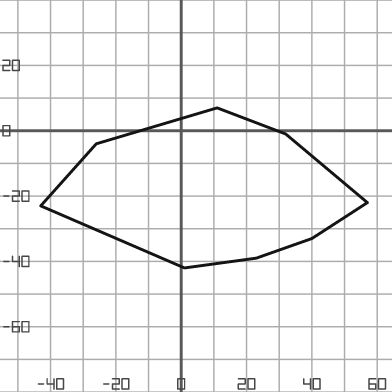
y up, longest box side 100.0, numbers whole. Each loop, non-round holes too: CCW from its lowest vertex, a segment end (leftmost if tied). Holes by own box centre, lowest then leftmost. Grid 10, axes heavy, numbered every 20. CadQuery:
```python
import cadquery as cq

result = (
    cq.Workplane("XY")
    .moveTo(1.0, -42.0)
    .lineTo(23.0, -39.0)
    .lineTo(40.0, -33.0)
    .lineTo(57.0, -22.0)
    .lineTo(32.0, -1.0)
    .lineTo(11.0, 7.0)
    .lineTo(-26.0, -4.0)
    .lineTo(-43.0, -23.0)
    .close()
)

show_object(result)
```